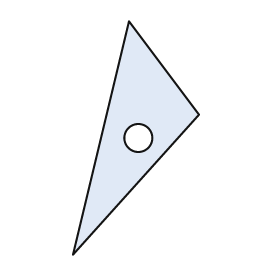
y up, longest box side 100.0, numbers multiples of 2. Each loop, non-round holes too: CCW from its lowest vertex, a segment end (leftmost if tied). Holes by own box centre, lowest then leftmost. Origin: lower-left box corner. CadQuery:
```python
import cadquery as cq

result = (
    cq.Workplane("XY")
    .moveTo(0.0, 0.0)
    .lineTo(54.0, 60.0)
    .lineTo(24.0, 100.0)
    .close()
    .moveTo(28.0, 50.0)
    .circle(6.0)
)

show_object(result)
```